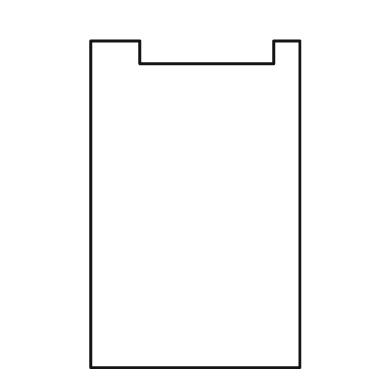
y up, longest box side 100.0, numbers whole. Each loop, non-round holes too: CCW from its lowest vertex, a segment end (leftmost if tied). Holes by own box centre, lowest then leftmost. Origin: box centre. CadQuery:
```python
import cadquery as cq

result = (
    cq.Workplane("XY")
    .moveTo(-32.0, -50.0)
    .lineTo(32.0, -50.0)
    .lineTo(32.0, 50.0)
    .lineTo(24.0, 50.0)
    .lineTo(24.0, 43.0)
    .lineTo(-17.0, 43.0)
    .lineTo(-17.0, 50.0)
    .lineTo(-32.0, 50.0)
    .close()
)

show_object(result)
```